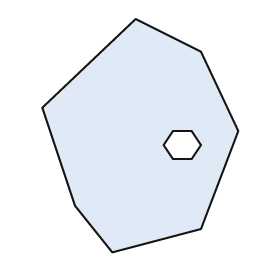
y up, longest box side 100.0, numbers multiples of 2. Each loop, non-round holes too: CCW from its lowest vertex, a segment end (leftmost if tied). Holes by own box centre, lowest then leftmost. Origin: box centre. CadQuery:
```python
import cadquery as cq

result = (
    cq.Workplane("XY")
    .moveTo(-12.0, -50.0)
    .lineTo(26.0, -40.0)
    .lineTo(42.0, 2.0)
    .lineTo(26.0, 36.0)
    .lineTo(-2.0, 50.0)
    .lineTo(-42.0, 12.0)
    .lineTo(-28.0, -30.0)
    .close()
    .moveTo(14.0, -10.0)
    .lineTo(22.0, -10.0)
    .lineTo(26.0, -4.0)
    .lineTo(22.0, 2.0)
    .lineTo(14.0, 2.0)
    .lineTo(10.0, -4.0)
    .close()
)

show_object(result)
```